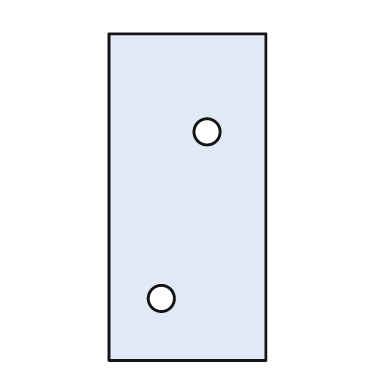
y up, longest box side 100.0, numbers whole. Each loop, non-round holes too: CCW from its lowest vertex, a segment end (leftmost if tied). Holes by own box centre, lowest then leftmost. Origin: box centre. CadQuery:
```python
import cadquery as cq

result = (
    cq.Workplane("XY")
    .moveTo(-24.0, -50.0)
    .lineTo(24.0, -50.0)
    .lineTo(24.0, 50.0)
    .lineTo(-24.0, 50.0)
    .close()
    .moveTo(-8.0, -31.0)
    .circle(4.0)
    .moveTo(6.0, 20.0)
    .circle(4.0)
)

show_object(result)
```